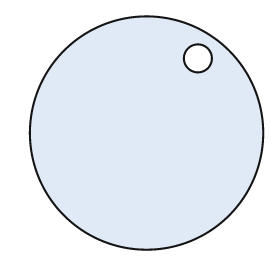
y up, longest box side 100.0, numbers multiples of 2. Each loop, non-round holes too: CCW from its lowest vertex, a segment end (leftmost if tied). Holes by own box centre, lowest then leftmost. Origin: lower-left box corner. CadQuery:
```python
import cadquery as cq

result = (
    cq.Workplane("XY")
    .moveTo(50.0, 50.0)
    .circle(50.0)
    .moveTo(72.0, 82.0)
    .circle(6.0)
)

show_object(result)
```